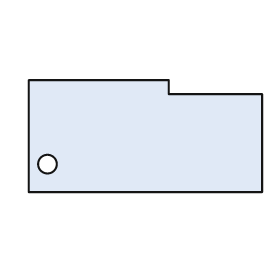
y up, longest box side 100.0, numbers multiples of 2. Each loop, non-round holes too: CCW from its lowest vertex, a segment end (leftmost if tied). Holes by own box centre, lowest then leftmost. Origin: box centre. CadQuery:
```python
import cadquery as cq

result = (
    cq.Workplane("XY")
    .moveTo(-50.0, -24.0)
    .lineTo(50.0, -24.0)
    .lineTo(50.0, 18.0)
    .lineTo(10.0, 18.0)
    .lineTo(10.0, 24.0)
    .lineTo(-50.0, 24.0)
    .close()
    .moveTo(-42.0, -12.0)
    .circle(4.0)
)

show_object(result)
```